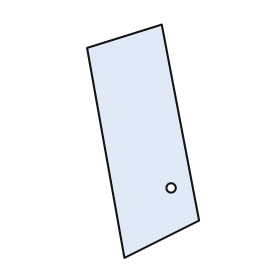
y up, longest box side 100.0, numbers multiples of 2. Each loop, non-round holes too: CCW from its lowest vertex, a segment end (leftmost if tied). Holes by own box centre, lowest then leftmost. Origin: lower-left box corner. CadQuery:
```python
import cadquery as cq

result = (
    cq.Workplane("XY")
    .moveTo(16.0, 0.0)
    .lineTo(48.0, 16.0)
    .lineTo(32.0, 100.0)
    .lineTo(0.0, 90.0)
    .close()
    .moveTo(36.0, 30.0)
    .circle(2.0)
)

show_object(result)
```